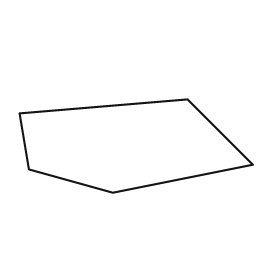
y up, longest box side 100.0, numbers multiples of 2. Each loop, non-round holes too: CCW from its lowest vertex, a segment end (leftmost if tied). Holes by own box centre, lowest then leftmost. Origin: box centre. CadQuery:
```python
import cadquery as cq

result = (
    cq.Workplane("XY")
    .moveTo(-10.0, -20.0)
    .lineTo(50.0, -8.0)
    .lineTo(22.0, 20.0)
    .lineTo(-50.0, 14.0)
    .lineTo(-46.0, -10.0)
    .close()
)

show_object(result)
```